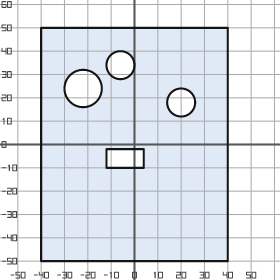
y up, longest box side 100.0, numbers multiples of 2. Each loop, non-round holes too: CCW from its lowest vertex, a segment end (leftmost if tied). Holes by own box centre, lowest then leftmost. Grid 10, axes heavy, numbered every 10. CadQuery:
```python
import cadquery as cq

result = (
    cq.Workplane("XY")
    .moveTo(-40.0, -50.0)
    .lineTo(40.0, -50.0)
    .lineTo(40.0, 50.0)
    .lineTo(-40.0, 50.0)
    .close()
    .moveTo(-12.0, -10.0)
    .lineTo(4.0, -10.0)
    .lineTo(4.0, -2.0)
    .lineTo(-12.0, -2.0)
    .close()
    .moveTo(20.0, 18.0)
    .circle(6.0)
    .moveTo(-22.0, 24.0)
    .circle(8.0)
    .moveTo(-6.0, 34.0)
    .circle(6.0)
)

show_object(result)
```